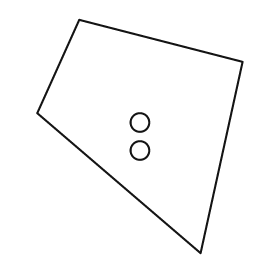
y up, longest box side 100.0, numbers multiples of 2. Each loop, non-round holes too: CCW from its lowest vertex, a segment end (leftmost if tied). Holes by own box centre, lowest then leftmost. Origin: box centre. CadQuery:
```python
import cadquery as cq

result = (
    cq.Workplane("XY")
    .moveTo(26.0, -50.0)
    .lineTo(44.0, 32.0)
    .lineTo(-26.0, 50.0)
    .lineTo(-44.0, 10.0)
    .close()
    .moveTo(0.0, -6.0)
    .circle(4.0)
    .moveTo(0.0, 6.0)
    .circle(4.0)
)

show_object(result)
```